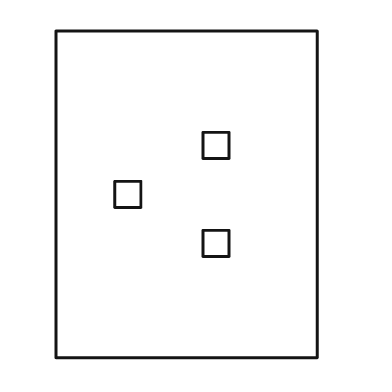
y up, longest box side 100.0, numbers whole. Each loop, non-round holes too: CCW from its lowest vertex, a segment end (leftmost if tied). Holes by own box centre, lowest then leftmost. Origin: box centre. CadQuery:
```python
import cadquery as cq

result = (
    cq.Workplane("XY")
    .moveTo(-40.0, -50.0)
    .lineTo(40.0, -50.0)
    .lineTo(40.0, 50.0)
    .lineTo(-40.0, 50.0)
    .close()
    .moveTo(5.0, -19.0)
    .lineTo(13.0, -19.0)
    .lineTo(13.0, -11.0)
    .lineTo(5.0, -11.0)
    .close()
    .moveTo(-22.0, -4.0)
    .lineTo(-14.0, -4.0)
    .lineTo(-14.0, 4.0)
    .lineTo(-22.0, 4.0)
    .close()
    .moveTo(5.0, 11.0)
    .lineTo(13.0, 11.0)
    .lineTo(13.0, 19.0)
    .lineTo(5.0, 19.0)
    .close()
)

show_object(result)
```